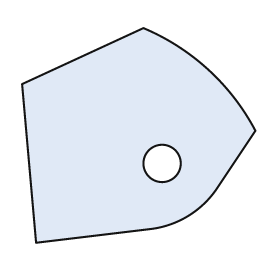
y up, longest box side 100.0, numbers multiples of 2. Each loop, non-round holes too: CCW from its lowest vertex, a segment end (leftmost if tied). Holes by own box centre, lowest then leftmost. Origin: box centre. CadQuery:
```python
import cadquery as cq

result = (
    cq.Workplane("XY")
    .moveTo(-44.0, -46.0)
    .lineTo(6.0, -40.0)
    .threePointArc((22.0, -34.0), (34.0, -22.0))
    .lineTo(50.0, 2.0)
    .threePointArc((30.0, 28.0), (2.0, 46.0))
    .lineTo(-50.0, 22.0)
    .close()
    .moveTo(10.0, -12.0)
    .circle(8.0)
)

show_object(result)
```